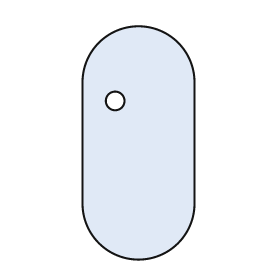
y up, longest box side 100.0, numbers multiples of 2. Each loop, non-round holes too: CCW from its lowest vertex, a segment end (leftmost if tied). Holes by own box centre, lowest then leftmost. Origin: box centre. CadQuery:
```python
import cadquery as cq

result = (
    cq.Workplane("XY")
    .moveTo(-24.0, -26.0)
    .threePointArc((0.0, -50.0), (24.0, -26.0))
    .lineTo(24.0, 26.0)
    .threePointArc((0.0, 50.0), (-24.0, 26.0))
    .close()
    .moveTo(-10.0, 18.0)
    .circle(4.0)
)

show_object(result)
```